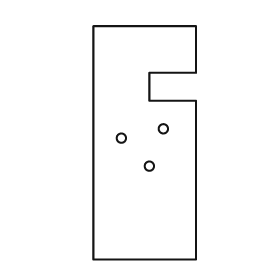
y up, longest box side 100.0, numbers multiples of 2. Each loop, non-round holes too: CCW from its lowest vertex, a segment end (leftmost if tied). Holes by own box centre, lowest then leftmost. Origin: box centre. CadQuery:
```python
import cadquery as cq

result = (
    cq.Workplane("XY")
    .moveTo(-22.0, -50.0)
    .lineTo(22.0, -50.0)
    .lineTo(22.0, 18.0)
    .lineTo(2.0, 18.0)
    .lineTo(2.0, 30.0)
    .lineTo(22.0, 30.0)
    .lineTo(22.0, 50.0)
    .lineTo(-22.0, 50.0)
    .close()
    .moveTo(2.0, -10.0)
    .circle(2.0)
    .moveTo(-10.0, 2.0)
    .circle(2.0)
    .moveTo(8.0, 6.0)
    .circle(2.0)
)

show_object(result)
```